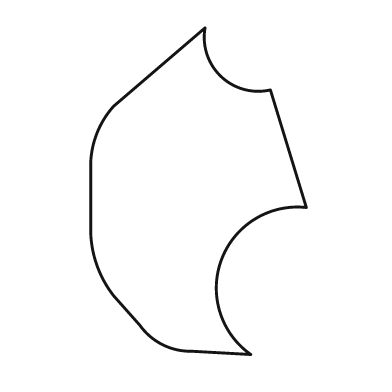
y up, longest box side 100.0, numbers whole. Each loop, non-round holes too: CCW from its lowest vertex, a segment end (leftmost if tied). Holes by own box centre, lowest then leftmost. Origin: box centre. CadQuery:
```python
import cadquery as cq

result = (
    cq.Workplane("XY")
    .moveTo(16.0, -50.0)
    .threePointArc((7.0, -21.0), (33.0, -5.0))
    .lineTo(22.0, 31.0)
    .threePointArc((7.0, 35.0), (2.0, 50.0))
    .lineTo(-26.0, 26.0)
    .threePointArc((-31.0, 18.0), (-33.0, 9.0))
    .lineTo(-33.0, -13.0)
    .threePointArc((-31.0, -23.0), (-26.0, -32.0))
    .lineTo(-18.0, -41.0)
    .threePointArc((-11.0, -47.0), (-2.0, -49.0))
    .close()
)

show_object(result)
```